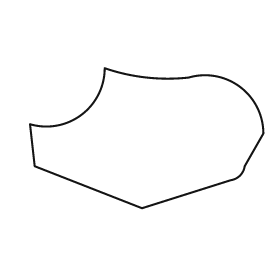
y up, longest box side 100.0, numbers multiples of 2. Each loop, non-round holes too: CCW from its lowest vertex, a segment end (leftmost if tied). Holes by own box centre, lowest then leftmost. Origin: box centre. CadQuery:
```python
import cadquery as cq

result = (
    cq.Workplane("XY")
    .moveTo(-2.0, -30.0)
    .lineTo(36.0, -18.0)
    .threePointArc((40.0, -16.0), (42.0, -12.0))
    .lineTo(50.0, 2.0)
    .threePointArc((40.0, 22.0), (18.0, 26.0))
    .threePointArc((0.0, 26.0), (-18.0, 30.0))
    .threePointArc((-28.0, 10.0), (-50.0, 6.0))
    .lineTo(-48.0, -12.0)
    .close()
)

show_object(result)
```